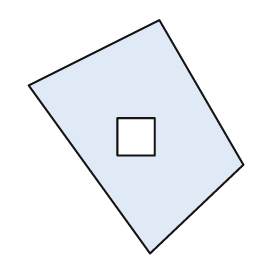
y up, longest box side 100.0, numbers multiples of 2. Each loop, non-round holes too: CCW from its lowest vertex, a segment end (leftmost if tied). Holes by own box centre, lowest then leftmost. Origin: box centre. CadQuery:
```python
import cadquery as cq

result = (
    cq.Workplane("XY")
    .moveTo(6.0, -50.0)
    .lineTo(46.0, -12.0)
    .lineTo(10.0, 50.0)
    .lineTo(-46.0, 22.0)
    .close()
    .moveTo(-8.0, -8.0)
    .lineTo(8.0, -8.0)
    .lineTo(8.0, 8.0)
    .lineTo(-8.0, 8.0)
    .close()
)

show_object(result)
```